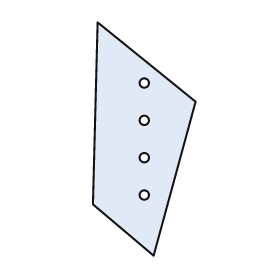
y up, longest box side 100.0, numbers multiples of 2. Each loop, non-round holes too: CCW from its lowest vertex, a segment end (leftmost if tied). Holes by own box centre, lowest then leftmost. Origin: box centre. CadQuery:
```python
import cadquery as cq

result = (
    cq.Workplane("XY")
    .moveTo(4.0, -50.0)
    .lineTo(22.0, 16.0)
    .lineTo(-20.0, 50.0)
    .lineTo(-22.0, -28.0)
    .close()
    .moveTo(0.0, -24.0)
    .circle(2.0)
    .moveTo(0.0, -8.0)
    .circle(2.0)
    .moveTo(0.0, 8.0)
    .circle(2.0)
    .moveTo(0.0, 24.0)
    .circle(2.0)
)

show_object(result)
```